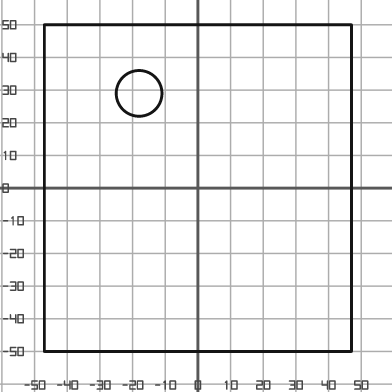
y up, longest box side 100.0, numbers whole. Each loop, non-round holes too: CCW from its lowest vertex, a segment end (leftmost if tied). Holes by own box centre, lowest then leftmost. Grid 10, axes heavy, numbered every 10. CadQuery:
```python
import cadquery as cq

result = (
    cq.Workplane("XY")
    .moveTo(-47.0, -50.0)
    .lineTo(47.0, -50.0)
    .lineTo(47.0, 50.0)
    .lineTo(-47.0, 50.0)
    .close()
    .moveTo(-18.0, 29.0)
    .circle(7.0)
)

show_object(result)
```